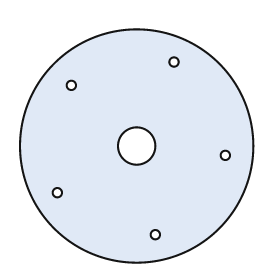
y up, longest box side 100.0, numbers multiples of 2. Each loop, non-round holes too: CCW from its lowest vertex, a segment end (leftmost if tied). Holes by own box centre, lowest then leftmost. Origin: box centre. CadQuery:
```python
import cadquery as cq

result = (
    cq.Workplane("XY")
    .moveTo(0.0, 0.0)
    .circle(50.0)
    .moveTo(8.0, -38.0)
    .circle(2.0)
    .moveTo(-34.0, -20.0)
    .circle(2.0)
    .moveTo(38.0, -4.0)
    .circle(2.0)
    .moveTo(0.0, 0.0)
    .circle(8.0)
    .moveTo(-28.0, 26.0)
    .circle(2.0)
    .moveTo(16.0, 36.0)
    .circle(2.0)
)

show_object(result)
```